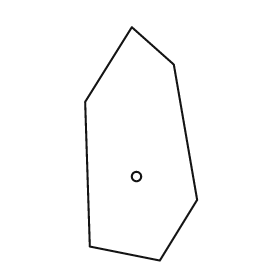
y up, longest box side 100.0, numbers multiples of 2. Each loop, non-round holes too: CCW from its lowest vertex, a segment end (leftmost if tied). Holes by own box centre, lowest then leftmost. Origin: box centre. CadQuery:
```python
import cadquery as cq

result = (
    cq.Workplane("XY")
    .moveTo(8.0, -50.0)
    .lineTo(24.0, -24.0)
    .lineTo(14.0, 34.0)
    .lineTo(-4.0, 50.0)
    .lineTo(-24.0, 18.0)
    .lineTo(-22.0, -44.0)
    .close()
    .moveTo(-2.0, -14.0)
    .circle(2.0)
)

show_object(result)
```